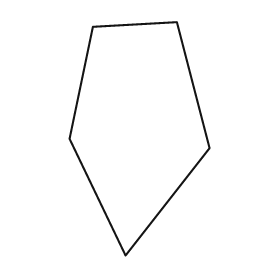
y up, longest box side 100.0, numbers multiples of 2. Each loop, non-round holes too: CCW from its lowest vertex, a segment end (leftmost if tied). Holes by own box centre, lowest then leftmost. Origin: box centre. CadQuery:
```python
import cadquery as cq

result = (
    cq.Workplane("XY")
    .moveTo(-6.0, -50.0)
    .lineTo(30.0, -4.0)
    .lineTo(16.0, 50.0)
    .lineTo(-20.0, 48.0)
    .lineTo(-30.0, 0.0)
    .close()
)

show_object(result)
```